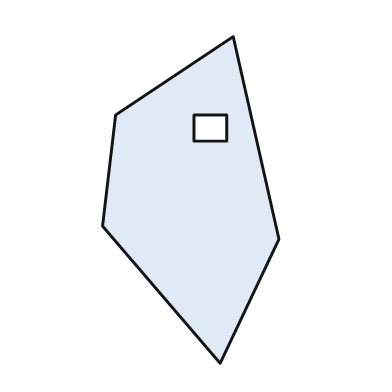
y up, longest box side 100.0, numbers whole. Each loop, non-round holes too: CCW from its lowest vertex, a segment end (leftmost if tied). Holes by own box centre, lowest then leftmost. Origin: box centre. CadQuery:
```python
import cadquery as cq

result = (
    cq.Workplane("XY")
    .moveTo(9.0, -50.0)
    .lineTo(27.0, -12.0)
    .lineTo(13.0, 50.0)
    .lineTo(-23.0, 26.0)
    .lineTo(-27.0, -8.0)
    .close()
    .moveTo(1.0, 18.0)
    .lineTo(11.0, 18.0)
    .lineTo(11.0, 26.0)
    .lineTo(1.0, 26.0)
    .close()
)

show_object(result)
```